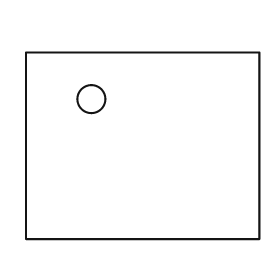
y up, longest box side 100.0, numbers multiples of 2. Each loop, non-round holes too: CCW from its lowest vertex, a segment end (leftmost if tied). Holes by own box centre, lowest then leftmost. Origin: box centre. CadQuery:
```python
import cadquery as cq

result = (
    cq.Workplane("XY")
    .moveTo(-50.0, -40.0)
    .lineTo(50.0, -40.0)
    .lineTo(50.0, 40.0)
    .lineTo(-50.0, 40.0)
    .close()
    .moveTo(-22.0, 20.0)
    .circle(6.0)
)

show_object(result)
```